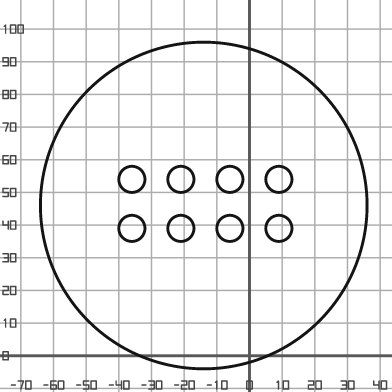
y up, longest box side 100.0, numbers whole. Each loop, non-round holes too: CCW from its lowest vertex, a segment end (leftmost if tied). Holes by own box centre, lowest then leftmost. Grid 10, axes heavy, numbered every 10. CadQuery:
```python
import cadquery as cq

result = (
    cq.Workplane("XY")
    .moveTo(-14.0, 46.0)
    .circle(50.0)
    .moveTo(-36.0, 39.0)
    .circle(4.0)
    .moveTo(-21.0, 39.0)
    .circle(4.0)
    .moveTo(-6.0, 39.0)
    .circle(4.0)
    .moveTo(9.0, 39.0)
    .circle(4.0)
    .moveTo(-36.0, 54.0)
    .circle(4.0)
    .moveTo(-21.0, 54.0)
    .circle(4.0)
    .moveTo(-6.0, 54.0)
    .circle(4.0)
    .moveTo(9.0, 54.0)
    .circle(4.0)
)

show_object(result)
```